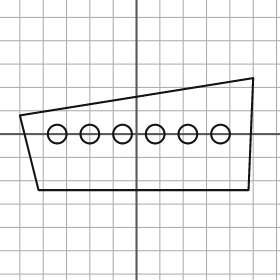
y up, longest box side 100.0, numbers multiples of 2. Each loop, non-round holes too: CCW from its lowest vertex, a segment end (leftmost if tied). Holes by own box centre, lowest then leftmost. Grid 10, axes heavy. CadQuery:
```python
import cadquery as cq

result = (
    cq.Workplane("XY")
    .moveTo(-42.0, -24.0)
    .lineTo(48.0, -24.0)
    .lineTo(50.0, 24.0)
    .lineTo(-50.0, 8.0)
    .close()
    .moveTo(-34.0, 0.0)
    .circle(4.0)
    .moveTo(-20.0, 0.0)
    .circle(4.0)
    .moveTo(-6.0, 0.0)
    .circle(4.0)
    .moveTo(8.0, 0.0)
    .circle(4.0)
    .moveTo(22.0, 0.0)
    .circle(4.0)
    .moveTo(36.0, 0.0)
    .circle(4.0)
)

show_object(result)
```